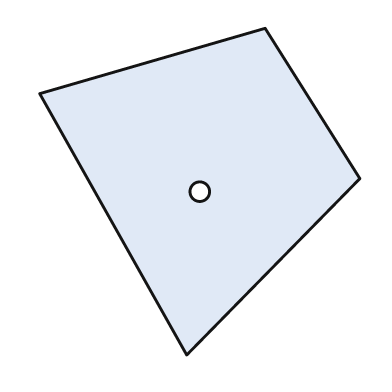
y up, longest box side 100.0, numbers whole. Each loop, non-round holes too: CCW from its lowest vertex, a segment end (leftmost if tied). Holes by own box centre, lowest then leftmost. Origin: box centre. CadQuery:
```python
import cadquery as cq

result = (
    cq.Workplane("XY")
    .moveTo(-4.0, -50.0)
    .lineTo(49.0, 4.0)
    .lineTo(20.0, 50.0)
    .lineTo(-49.0, 30.0)
    .close()
    .moveTo(0.0, 0.0)
    .circle(3.0)
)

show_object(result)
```